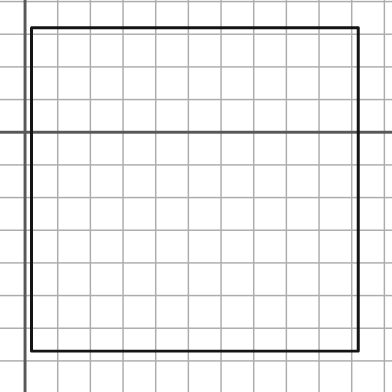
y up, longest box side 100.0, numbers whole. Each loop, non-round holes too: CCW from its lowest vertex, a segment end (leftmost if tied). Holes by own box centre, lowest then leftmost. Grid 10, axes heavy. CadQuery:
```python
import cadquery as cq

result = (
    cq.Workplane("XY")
    .moveTo(2.0, -67.0)
    .lineTo(102.0, -67.0)
    .lineTo(102.0, 32.0)
    .lineTo(2.0, 32.0)
    .close()
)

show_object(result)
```